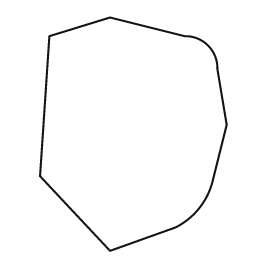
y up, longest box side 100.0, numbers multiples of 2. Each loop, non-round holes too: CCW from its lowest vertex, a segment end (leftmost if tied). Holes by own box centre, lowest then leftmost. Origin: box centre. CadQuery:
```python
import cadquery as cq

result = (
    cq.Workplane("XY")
    .moveTo(-10.0, -50.0)
    .lineTo(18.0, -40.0)
    .threePointArc((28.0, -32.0), (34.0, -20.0))
    .lineTo(40.0, 4.0)
    .lineTo(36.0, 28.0)
    .threePointArc((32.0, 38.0), (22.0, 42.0))
    .lineTo(-10.0, 50.0)
    .lineTo(-36.0, 42.0)
    .lineTo(-40.0, -18.0)
    .close()
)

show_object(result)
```